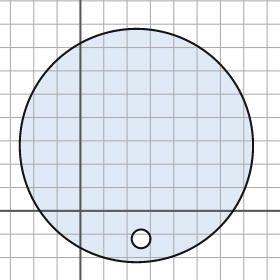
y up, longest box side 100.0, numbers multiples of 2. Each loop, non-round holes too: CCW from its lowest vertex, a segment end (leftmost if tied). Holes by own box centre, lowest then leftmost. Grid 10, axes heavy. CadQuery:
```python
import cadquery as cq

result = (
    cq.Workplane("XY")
    .moveTo(24.0, 28.0)
    .circle(50.0)
    .moveTo(26.0, -12.0)
    .circle(4.0)
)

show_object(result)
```